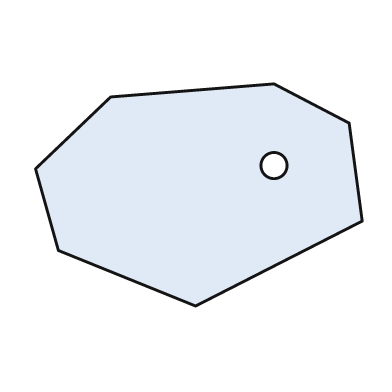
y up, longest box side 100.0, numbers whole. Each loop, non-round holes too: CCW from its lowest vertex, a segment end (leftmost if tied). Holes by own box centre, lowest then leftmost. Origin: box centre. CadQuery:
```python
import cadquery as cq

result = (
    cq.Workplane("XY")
    .moveTo(-1.0, -34.0)
    .lineTo(50.0, -8.0)
    .lineTo(46.0, 22.0)
    .lineTo(23.0, 34.0)
    .lineTo(-27.0, 30.0)
    .lineTo(-50.0, 8.0)
    .lineTo(-43.0, -17.0)
    .close()
    .moveTo(23.0, 9.0)
    .circle(4.0)
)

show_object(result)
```